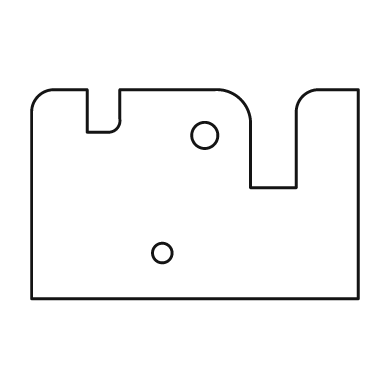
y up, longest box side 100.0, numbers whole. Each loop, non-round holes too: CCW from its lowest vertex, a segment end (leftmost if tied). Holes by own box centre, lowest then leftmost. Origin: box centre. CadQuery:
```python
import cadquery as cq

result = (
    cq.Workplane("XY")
    .moveTo(-50.0, -32.0)
    .lineTo(50.0, -32.0)
    .lineTo(50.0, 32.0)
    .lineTo(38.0, 32.0)
    .threePointArc((33.0, 30.0), (31.0, 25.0))
    .lineTo(31.0, 2.0)
    .lineTo(17.0, 2.0)
    .lineTo(17.0, 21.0)
    .threePointArc((14.0, 29.0), (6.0, 32.0))
    .lineTo(-23.0, 32.0)
    .lineTo(-23.0, 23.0)
    .threePointArc((-24.0, 20.0), (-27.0, 19.0))
    .lineTo(-33.0, 19.0)
    .lineTo(-33.0, 32.0)
    .lineTo(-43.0, 32.0)
    .threePointArc((-48.0, 30.0), (-50.0, 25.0))
    .close()
    .moveTo(-10.0, -18.0)
    .circle(3.0)
    .moveTo(3.0, 18.0)
    .circle(4.0)
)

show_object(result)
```